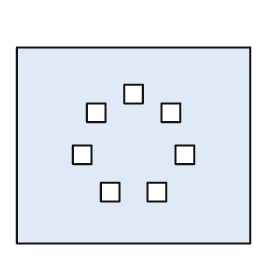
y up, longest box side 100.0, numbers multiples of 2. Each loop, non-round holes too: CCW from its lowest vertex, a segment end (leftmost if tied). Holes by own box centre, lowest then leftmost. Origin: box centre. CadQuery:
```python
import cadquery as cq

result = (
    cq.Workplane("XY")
    .moveTo(-50.0, -42.0)
    .lineTo(50.0, -42.0)
    .lineTo(50.0, 42.0)
    .lineTo(-50.0, 42.0)
    .close()
    .moveTo(-14.0, -24.0)
    .lineTo(-6.0, -24.0)
    .lineTo(-6.0, -16.0)
    .lineTo(-14.0, -16.0)
    .close()
    .moveTo(6.0, -24.0)
    .lineTo(14.0, -24.0)
    .lineTo(14.0, -16.0)
    .lineTo(6.0, -16.0)
    .close()
    .moveTo(-26.0, -8.0)
    .lineTo(-18.0, -8.0)
    .lineTo(-18.0, 0.0)
    .lineTo(-26.0, 0.0)
    .close()
    .moveTo(18.0, -8.0)
    .lineTo(26.0, -8.0)
    .lineTo(26.0, 0.0)
    .lineTo(18.0, 0.0)
    .close()
    .moveTo(-20.0, 10.0)
    .lineTo(-12.0, 10.0)
    .lineTo(-12.0, 18.0)
    .lineTo(-20.0, 18.0)
    .close()
    .moveTo(12.0, 10.0)
    .lineTo(20.0, 10.0)
    .lineTo(20.0, 18.0)
    .lineTo(12.0, 18.0)
    .close()
    .moveTo(-4.0, 18.0)
    .lineTo(4.0, 18.0)
    .lineTo(4.0, 26.0)
    .lineTo(-4.0, 26.0)
    .close()
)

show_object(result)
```